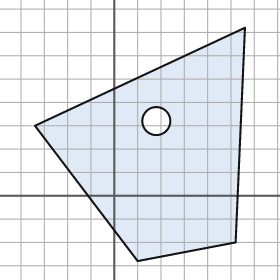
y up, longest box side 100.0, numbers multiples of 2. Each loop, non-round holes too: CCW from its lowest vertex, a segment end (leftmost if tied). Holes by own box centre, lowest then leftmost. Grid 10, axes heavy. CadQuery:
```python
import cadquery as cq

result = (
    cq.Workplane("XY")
    .moveTo(10.0, -28.0)
    .lineTo(52.0, -20.0)
    .lineTo(56.0, 72.0)
    .lineTo(-34.0, 30.0)
    .close()
    .moveTo(18.0, 32.0)
    .circle(6.0)
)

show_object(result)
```